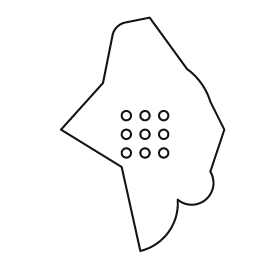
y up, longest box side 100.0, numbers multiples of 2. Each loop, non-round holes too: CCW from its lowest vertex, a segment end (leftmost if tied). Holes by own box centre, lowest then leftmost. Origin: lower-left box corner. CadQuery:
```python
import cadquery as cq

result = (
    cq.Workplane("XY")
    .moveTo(34.0, 0.0)
    .threePointArc((46.0, 8.0), (50.0, 22.0))
    .threePointArc((62.0, 22.0), (64.0, 34.0))
    .lineTo(70.0, 52.0)
    .lineTo(64.0, 64.0)
    .threePointArc((60.0, 72.0), (54.0, 78.0))
    .lineTo(38.0, 100.0)
    .lineTo(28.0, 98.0)
    .threePointArc((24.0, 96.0), (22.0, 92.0))
    .lineTo(18.0, 72.0)
    .lineTo(0.0, 52.0)
    .lineTo(26.0, 36.0)
    .close()
    .moveTo(28.0, 42.0)
    .circle(2.0)
    .moveTo(36.0, 42.0)
    .circle(2.0)
    .moveTo(44.0, 42.0)
    .circle(2.0)
    .moveTo(28.0, 50.0)
    .circle(2.0)
    .moveTo(36.0, 50.0)
    .circle(2.0)
    .moveTo(44.0, 50.0)
    .circle(2.0)
    .moveTo(28.0, 58.0)
    .circle(2.0)
    .moveTo(36.0, 58.0)
    .circle(2.0)
    .moveTo(44.0, 58.0)
    .circle(2.0)
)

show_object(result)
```